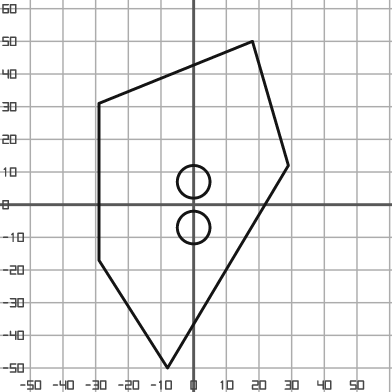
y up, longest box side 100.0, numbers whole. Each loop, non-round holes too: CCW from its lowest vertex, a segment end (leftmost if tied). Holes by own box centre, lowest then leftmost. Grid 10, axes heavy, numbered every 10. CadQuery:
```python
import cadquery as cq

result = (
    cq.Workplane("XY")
    .moveTo(-8.0, -50.0)
    .lineTo(29.0, 12.0)
    .lineTo(18.0, 50.0)
    .lineTo(-29.0, 31.0)
    .lineTo(-29.0, -17.0)
    .close()
    .moveTo(0.0, -7.0)
    .circle(5.0)
    .moveTo(0.0, 7.0)
    .circle(5.0)
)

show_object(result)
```